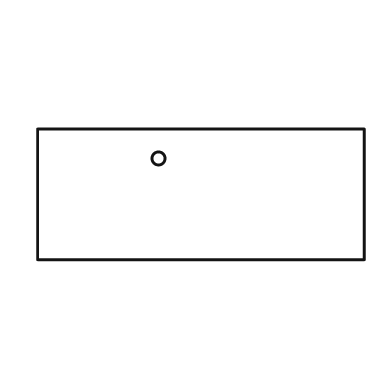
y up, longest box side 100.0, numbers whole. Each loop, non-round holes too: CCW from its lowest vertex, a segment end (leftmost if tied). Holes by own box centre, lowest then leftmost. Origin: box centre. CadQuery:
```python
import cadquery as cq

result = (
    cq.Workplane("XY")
    .moveTo(-50.0, -20.0)
    .lineTo(50.0, -20.0)
    .lineTo(50.0, 20.0)
    .lineTo(-50.0, 20.0)
    .close()
    .moveTo(-13.0, 11.0)
    .circle(2.0)
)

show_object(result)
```